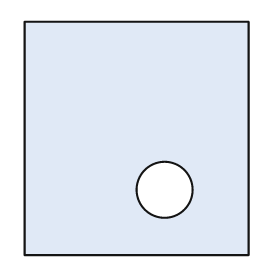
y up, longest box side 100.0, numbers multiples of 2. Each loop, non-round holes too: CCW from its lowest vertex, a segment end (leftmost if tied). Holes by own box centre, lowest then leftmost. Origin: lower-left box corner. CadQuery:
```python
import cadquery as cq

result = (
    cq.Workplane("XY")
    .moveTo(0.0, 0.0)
    .lineTo(96.0, 0.0)
    .lineTo(96.0, 100.0)
    .lineTo(0.0, 100.0)
    .close()
    .moveTo(60.0, 28.0)
    .circle(12.0)
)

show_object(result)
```